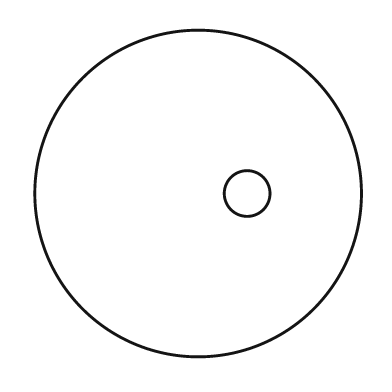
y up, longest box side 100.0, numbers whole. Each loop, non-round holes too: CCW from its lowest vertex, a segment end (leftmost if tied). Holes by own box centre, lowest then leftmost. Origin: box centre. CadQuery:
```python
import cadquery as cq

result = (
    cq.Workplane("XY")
    .moveTo(0.0, 0.0)
    .circle(50.0)
    .moveTo(15.0, 0.0)
    .circle(7.0)
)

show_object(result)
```